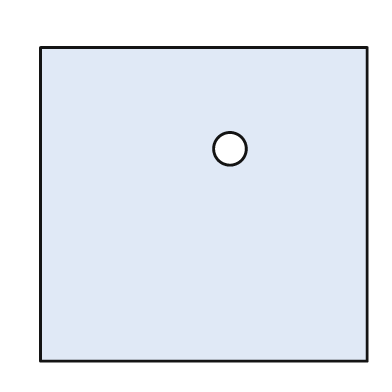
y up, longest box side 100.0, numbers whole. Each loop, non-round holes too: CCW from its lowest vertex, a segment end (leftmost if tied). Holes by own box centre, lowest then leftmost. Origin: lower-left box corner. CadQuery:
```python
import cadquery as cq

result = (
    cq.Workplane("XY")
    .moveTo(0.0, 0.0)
    .lineTo(100.0, 0.0)
    .lineTo(100.0, 96.0)
    .lineTo(0.0, 96.0)
    .close()
    .moveTo(58.0, 65.0)
    .circle(5.0)
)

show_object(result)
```